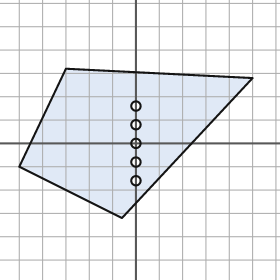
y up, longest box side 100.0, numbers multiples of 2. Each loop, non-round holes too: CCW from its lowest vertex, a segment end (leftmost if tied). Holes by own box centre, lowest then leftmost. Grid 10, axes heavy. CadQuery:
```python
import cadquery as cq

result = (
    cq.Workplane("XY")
    .moveTo(-6.0, -32.0)
    .lineTo(50.0, 28.0)
    .lineTo(-30.0, 32.0)
    .lineTo(-50.0, -10.0)
    .close()
    .moveTo(0.0, -16.0)
    .circle(2.0)
    .moveTo(0.0, -8.0)
    .circle(2.0)
    .moveTo(0.0, 0.0)
    .circle(2.0)
    .moveTo(0.0, 8.0)
    .circle(2.0)
    .moveTo(0.0, 16.0)
    .circle(2.0)
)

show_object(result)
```